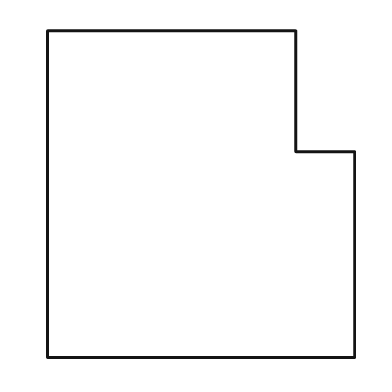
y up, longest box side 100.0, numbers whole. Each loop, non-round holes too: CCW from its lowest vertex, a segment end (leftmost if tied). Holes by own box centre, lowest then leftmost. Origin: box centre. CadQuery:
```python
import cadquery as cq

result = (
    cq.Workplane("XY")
    .moveTo(-47.0, -50.0)
    .lineTo(47.0, -50.0)
    .lineTo(47.0, 13.0)
    .lineTo(29.0, 13.0)
    .lineTo(29.0, 50.0)
    .lineTo(-47.0, 50.0)
    .close()
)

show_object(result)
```